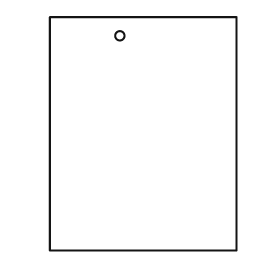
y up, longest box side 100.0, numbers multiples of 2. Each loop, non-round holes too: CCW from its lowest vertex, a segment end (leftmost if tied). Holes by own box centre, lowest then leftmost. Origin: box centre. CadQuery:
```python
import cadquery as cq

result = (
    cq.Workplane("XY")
    .moveTo(-40.0, -50.0)
    .lineTo(40.0, -50.0)
    .lineTo(40.0, 50.0)
    .lineTo(-40.0, 50.0)
    .close()
    .moveTo(-10.0, 42.0)
    .circle(2.0)
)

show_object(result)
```